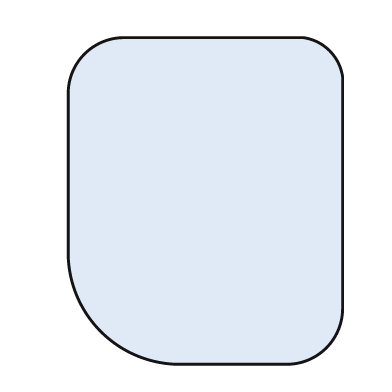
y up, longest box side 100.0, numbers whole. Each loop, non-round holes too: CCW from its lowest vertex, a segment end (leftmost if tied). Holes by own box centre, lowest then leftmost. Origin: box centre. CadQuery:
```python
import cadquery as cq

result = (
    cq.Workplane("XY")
    .moveTo(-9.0, -50.0)
    .lineTo(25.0, -50.0)
    .threePointArc((37.0, -45.0), (42.0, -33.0))
    .lineTo(42.0, 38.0)
    .threePointArc((38.0, 46.0), (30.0, 50.0))
    .lineTo(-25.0, 50.0)
    .threePointArc((-37.0, 45.0), (-42.0, 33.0))
    .lineTo(-42.0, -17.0)
    .threePointArc((-32.0, -40.0), (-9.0, -50.0))
    .close()
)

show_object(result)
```